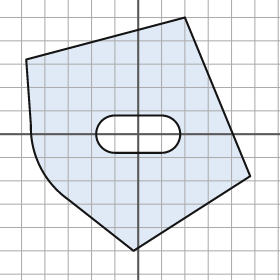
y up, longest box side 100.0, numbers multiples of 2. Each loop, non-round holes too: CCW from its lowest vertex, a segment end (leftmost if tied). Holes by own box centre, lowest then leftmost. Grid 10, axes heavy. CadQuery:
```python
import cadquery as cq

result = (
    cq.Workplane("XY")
    .moveTo(-2.0, -50.0)
    .lineTo(48.0, -18.0)
    .lineTo(20.0, 50.0)
    .lineTo(-48.0, 32.0)
    .lineTo(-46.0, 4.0)
    .threePointArc((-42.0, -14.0), (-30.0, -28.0))
    .close()
    .moveTo(-10.0, -8.0)
    .lineTo(10.0, -8.0)
    .threePointArc((18.0, 0.0), (10.0, 8.0))
    .lineTo(-10.0, 8.0)
    .threePointArc((-18.0, 0.0), (-10.0, -8.0))
    .close()
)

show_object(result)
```